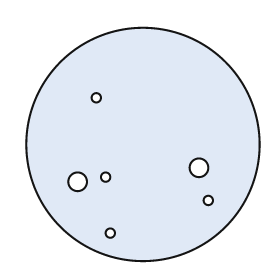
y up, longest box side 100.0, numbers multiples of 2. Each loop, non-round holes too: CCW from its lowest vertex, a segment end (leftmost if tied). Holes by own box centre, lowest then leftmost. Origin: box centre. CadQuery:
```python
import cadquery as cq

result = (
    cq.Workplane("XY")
    .moveTo(0.0, 0.0)
    .circle(50.0)
    .moveTo(-14.0, -38.0)
    .circle(2.0)
    .moveTo(28.0, -24.0)
    .circle(2.0)
    .moveTo(-28.0, -16.0)
    .circle(4.0)
    .moveTo(-16.0, -14.0)
    .circle(2.0)
    .moveTo(24.0, -10.0)
    .circle(4.0)
    .moveTo(-20.0, 20.0)
    .circle(2.0)
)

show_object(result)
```